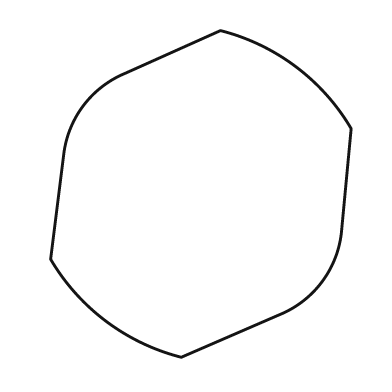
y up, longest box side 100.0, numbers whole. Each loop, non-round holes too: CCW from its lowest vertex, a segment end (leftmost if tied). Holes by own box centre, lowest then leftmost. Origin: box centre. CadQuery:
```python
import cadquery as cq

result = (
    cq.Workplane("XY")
    .moveTo(-6.0, -50.0)
    .lineTo(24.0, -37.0)
    .threePointArc((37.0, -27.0), (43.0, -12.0))
    .lineTo(46.0, 20.0)
    .threePointArc((29.0, 39.0), (6.0, 50.0))
    .lineTo(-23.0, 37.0)
    .threePointArc((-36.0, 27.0), (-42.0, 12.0))
    .lineTo(-46.0, -20.0)
    .threePointArc((-29.0, -39.0), (-6.0, -50.0))
    .close()
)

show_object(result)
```